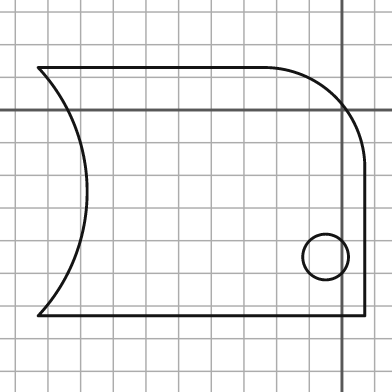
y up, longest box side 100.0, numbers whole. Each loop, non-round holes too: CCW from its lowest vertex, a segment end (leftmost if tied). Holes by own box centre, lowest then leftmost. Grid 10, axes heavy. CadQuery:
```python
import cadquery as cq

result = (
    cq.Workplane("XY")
    .moveTo(-93.0, -63.0)
    .lineTo(7.0, -63.0)
    .lineTo(7.0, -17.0)
    .threePointArc((-2.0, 4.0), (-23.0, 13.0))
    .lineTo(-93.0, 13.0)
    .threePointArc((-78.0, -25.0), (-93.0, -63.0))
    .close()
    .moveTo(-5.0, -45.0)
    .circle(7.0)
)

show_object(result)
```